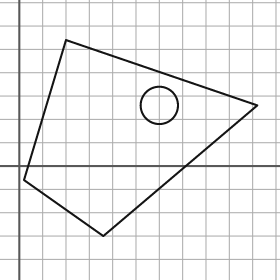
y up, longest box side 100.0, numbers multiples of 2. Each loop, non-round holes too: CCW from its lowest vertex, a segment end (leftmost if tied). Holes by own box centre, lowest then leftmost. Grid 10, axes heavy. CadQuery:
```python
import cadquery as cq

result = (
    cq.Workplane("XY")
    .moveTo(36.0, -30.0)
    .lineTo(102.0, 26.0)
    .lineTo(20.0, 54.0)
    .lineTo(2.0, -6.0)
    .close()
    .moveTo(60.0, 26.0)
    .circle(8.0)
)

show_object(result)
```